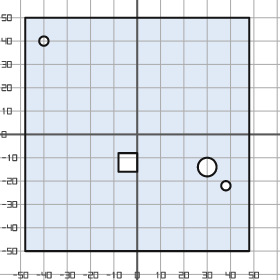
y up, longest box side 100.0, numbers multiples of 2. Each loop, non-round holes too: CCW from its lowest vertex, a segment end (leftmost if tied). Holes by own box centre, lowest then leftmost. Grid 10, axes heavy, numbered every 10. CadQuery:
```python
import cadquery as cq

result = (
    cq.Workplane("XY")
    .moveTo(-48.0, -50.0)
    .lineTo(48.0, -50.0)
    .lineTo(48.0, 50.0)
    .lineTo(-48.0, 50.0)
    .close()
    .moveTo(38.0, -22.0)
    .circle(2.0)
    .moveTo(30.0, -14.0)
    .circle(4.0)
    .moveTo(-8.0, -16.0)
    .lineTo(0.0, -16.0)
    .lineTo(0.0, -8.0)
    .lineTo(-8.0, -8.0)
    .close()
    .moveTo(-40.0, 40.0)
    .circle(2.0)
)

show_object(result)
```